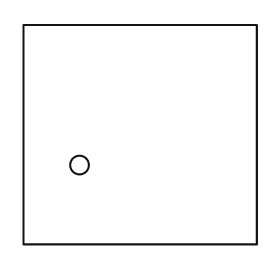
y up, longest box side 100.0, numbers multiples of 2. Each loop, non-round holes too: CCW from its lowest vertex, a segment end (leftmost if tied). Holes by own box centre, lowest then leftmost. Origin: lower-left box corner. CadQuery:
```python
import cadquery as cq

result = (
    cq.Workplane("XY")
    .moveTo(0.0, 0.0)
    .lineTo(100.0, 0.0)
    .lineTo(100.0, 94.0)
    .lineTo(0.0, 94.0)
    .close()
    .moveTo(24.0, 34.0)
    .circle(4.0)
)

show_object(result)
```